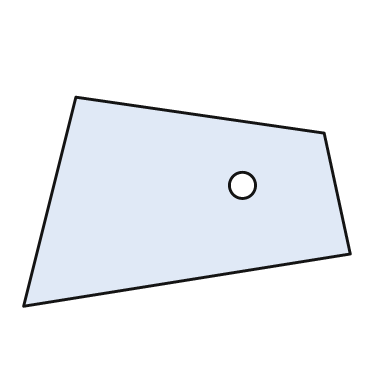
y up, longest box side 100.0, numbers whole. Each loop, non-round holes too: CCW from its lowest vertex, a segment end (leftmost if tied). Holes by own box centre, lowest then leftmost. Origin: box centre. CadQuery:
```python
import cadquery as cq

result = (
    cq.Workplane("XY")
    .moveTo(-50.0, -32.0)
    .lineTo(50.0, -16.0)
    .lineTo(42.0, 21.0)
    .lineTo(-34.0, 32.0)
    .close()
    .moveTo(17.0, 5.0)
    .circle(4.0)
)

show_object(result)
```